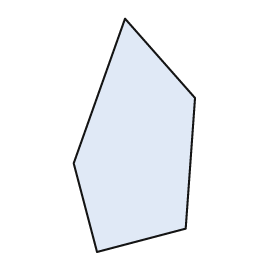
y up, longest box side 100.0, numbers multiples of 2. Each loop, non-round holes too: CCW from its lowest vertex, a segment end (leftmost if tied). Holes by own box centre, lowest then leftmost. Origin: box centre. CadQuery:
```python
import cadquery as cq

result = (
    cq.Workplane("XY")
    .moveTo(-16.0, -50.0)
    .lineTo(22.0, -40.0)
    .lineTo(26.0, 16.0)
    .lineTo(-4.0, 50.0)
    .lineTo(-26.0, -12.0)
    .close()
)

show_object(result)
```